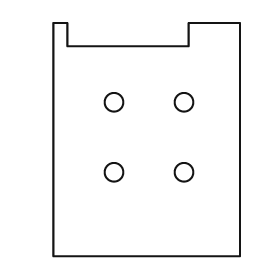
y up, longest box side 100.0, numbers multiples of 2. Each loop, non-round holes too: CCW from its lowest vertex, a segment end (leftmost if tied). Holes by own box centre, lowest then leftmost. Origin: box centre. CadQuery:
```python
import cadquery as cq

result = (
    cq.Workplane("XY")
    .moveTo(-40.0, -50.0)
    .lineTo(40.0, -50.0)
    .lineTo(40.0, 50.0)
    .lineTo(18.0, 50.0)
    .lineTo(18.0, 40.0)
    .lineTo(-34.0, 40.0)
    .lineTo(-34.0, 50.0)
    .lineTo(-40.0, 50.0)
    .close()
    .moveTo(-14.0, -14.0)
    .circle(4.0)
    .moveTo(16.0, -14.0)
    .circle(4.0)
    .moveTo(-14.0, 16.0)
    .circle(4.0)
    .moveTo(16.0, 16.0)
    .circle(4.0)
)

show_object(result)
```